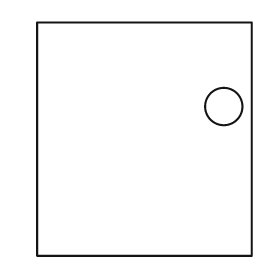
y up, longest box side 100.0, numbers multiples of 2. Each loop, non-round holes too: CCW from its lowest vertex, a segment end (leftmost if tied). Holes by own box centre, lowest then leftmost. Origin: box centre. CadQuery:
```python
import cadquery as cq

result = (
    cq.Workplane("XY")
    .moveTo(-46.0, -50.0)
    .lineTo(46.0, -50.0)
    .lineTo(46.0, 50.0)
    .lineTo(-46.0, 50.0)
    .close()
    .moveTo(34.0, 14.0)
    .circle(8.0)
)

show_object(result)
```